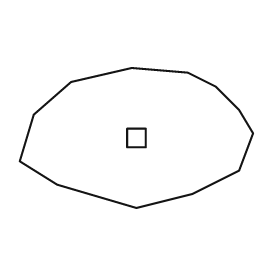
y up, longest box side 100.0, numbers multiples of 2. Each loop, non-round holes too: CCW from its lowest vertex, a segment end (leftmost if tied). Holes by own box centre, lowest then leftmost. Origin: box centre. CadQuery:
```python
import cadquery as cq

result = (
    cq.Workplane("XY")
    .moveTo(0.0, -30.0)
    .lineTo(24.0, -24.0)
    .lineTo(44.0, -14.0)
    .lineTo(50.0, 2.0)
    .lineTo(44.0, 12.0)
    .lineTo(34.0, 22.0)
    .lineTo(22.0, 28.0)
    .lineTo(-2.0, 30.0)
    .lineTo(-28.0, 24.0)
    .lineTo(-44.0, 10.0)
    .lineTo(-50.0, -10.0)
    .lineTo(-34.0, -20.0)
    .close()
    .moveTo(-4.0, -4.0)
    .lineTo(4.0, -4.0)
    .lineTo(4.0, 4.0)
    .lineTo(-4.0, 4.0)
    .close()
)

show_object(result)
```